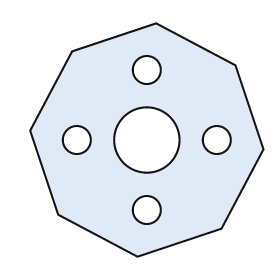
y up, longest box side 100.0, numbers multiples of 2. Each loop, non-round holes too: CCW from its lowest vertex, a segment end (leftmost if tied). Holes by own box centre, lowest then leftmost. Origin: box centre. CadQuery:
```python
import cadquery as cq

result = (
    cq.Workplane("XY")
    .moveTo(-4.0, -50.0)
    .lineTo(32.0, -38.0)
    .lineTo(50.0, -4.0)
    .lineTo(38.0, 32.0)
    .lineTo(4.0, 50.0)
    .lineTo(-32.0, 38.0)
    .lineTo(-50.0, 4.0)
    .lineTo(-38.0, -32.0)
    .close()
    .moveTo(0.0, -30.0)
    .circle(6.0)
    .moveTo(-30.0, 0.0)
    .circle(6.0)
    .moveTo(0.0, 0.0)
    .circle(14.0)
    .moveTo(30.0, 0.0)
    .circle(6.0)
    .moveTo(0.0, 30.0)
    .circle(6.0)
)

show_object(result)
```